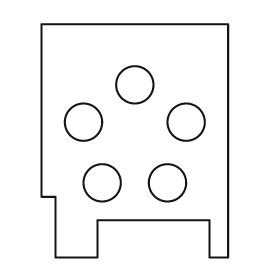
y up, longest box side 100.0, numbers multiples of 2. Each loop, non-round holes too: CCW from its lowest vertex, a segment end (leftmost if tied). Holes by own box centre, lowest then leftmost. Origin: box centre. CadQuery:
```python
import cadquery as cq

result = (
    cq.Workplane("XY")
    .moveTo(-34.0, -50.0)
    .lineTo(-16.0, -50.0)
    .lineTo(-16.0, -34.0)
    .lineTo(32.0, -34.0)
    .lineTo(32.0, -50.0)
    .lineTo(40.0, -50.0)
    .lineTo(40.0, 50.0)
    .lineTo(-40.0, 50.0)
    .lineTo(-40.0, -24.0)
    .lineTo(-34.0, -24.0)
    .close()
    .moveTo(-14.0, -18.0)
    .circle(8.0)
    .moveTo(14.0, -18.0)
    .circle(8.0)
    .moveTo(-22.0, 8.0)
    .circle(8.0)
    .moveTo(22.0, 8.0)
    .circle(8.0)
    .moveTo(0.0, 24.0)
    .circle(8.0)
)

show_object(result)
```